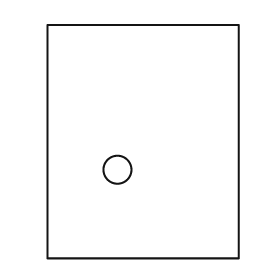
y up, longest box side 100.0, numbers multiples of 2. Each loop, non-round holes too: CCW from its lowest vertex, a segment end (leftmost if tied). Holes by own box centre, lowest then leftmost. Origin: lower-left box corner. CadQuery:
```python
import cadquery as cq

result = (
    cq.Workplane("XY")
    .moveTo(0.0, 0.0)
    .lineTo(82.0, 0.0)
    .lineTo(82.0, 100.0)
    .lineTo(0.0, 100.0)
    .close()
    .moveTo(30.0, 38.0)
    .circle(6.0)
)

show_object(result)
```